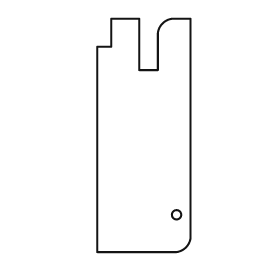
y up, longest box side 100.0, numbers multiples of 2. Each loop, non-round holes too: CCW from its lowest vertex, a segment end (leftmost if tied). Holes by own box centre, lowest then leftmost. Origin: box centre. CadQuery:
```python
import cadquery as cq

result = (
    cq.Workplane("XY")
    .moveTo(-20.0, -50.0)
    .lineTo(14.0, -50.0)
    .threePointArc((18.0, -48.0), (20.0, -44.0))
    .lineTo(20.0, 50.0)
    .lineTo(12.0, 50.0)
    .threePointArc((8.0, 48.0), (6.0, 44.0))
    .lineTo(6.0, 28.0)
    .lineTo(-2.0, 28.0)
    .lineTo(-2.0, 50.0)
    .lineTo(-14.0, 50.0)
    .lineTo(-14.0, 38.0)
    .lineTo(-20.0, 38.0)
    .close()
    .moveTo(14.0, -34.0)
    .circle(2.0)
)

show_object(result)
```